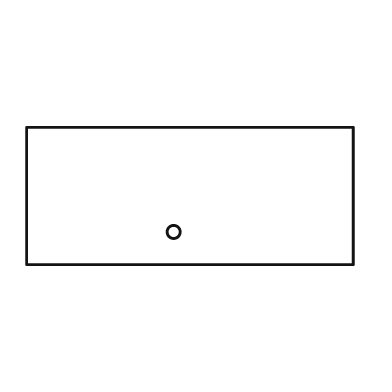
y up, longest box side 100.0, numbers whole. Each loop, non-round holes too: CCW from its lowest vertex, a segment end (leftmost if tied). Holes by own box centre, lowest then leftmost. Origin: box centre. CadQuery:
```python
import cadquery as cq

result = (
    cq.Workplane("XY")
    .moveTo(-50.0, -21.0)
    .lineTo(50.0, -21.0)
    .lineTo(50.0, 21.0)
    .lineTo(-50.0, 21.0)
    .close()
    .moveTo(-5.0, -11.0)
    .circle(2.0)
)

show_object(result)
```